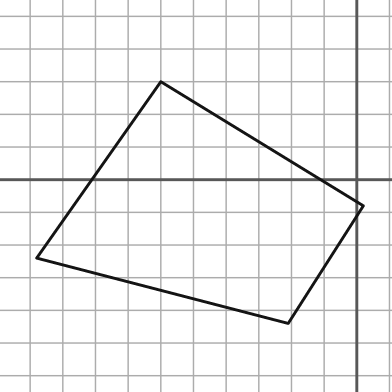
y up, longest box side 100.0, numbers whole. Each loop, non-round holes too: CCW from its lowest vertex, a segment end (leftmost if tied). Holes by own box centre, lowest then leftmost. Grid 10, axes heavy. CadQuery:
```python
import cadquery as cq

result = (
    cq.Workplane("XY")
    .moveTo(-21.0, -44.0)
    .lineTo(2.0, -8.0)
    .lineTo(-60.0, 30.0)
    .lineTo(-98.0, -24.0)
    .close()
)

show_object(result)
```